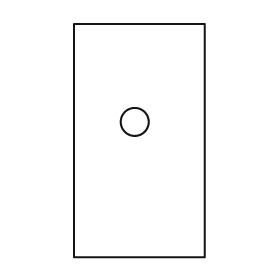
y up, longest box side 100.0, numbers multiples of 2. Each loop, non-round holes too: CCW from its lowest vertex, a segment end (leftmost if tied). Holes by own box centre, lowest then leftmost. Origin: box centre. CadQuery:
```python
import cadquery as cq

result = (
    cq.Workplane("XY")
    .moveTo(-28.0, -50.0)
    .lineTo(28.0, -50.0)
    .lineTo(28.0, 50.0)
    .lineTo(-28.0, 50.0)
    .close()
    .moveTo(-2.0, 8.0)
    .circle(6.0)
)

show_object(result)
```